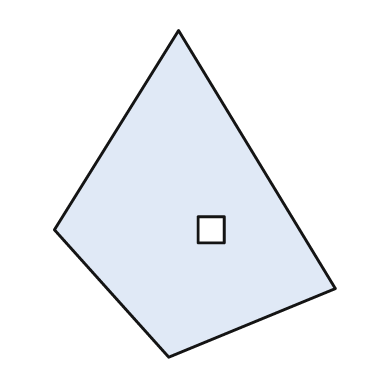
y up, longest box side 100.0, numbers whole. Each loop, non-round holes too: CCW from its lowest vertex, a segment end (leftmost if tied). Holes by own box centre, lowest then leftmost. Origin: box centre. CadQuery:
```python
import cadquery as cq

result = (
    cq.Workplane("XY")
    .moveTo(-8.0, -50.0)
    .lineTo(43.0, -29.0)
    .lineTo(-5.0, 50.0)
    .lineTo(-43.0, -11.0)
    .close()
    .moveTo(1.0, -15.0)
    .lineTo(9.0, -15.0)
    .lineTo(9.0, -7.0)
    .lineTo(1.0, -7.0)
    .close()
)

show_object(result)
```